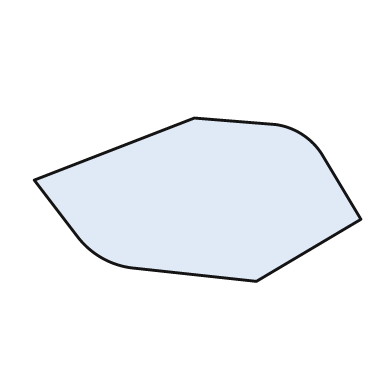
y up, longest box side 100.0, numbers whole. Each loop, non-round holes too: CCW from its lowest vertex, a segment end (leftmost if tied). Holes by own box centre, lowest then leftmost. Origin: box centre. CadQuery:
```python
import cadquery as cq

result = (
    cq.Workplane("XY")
    .moveTo(18.0, -25.0)
    .lineTo(50.0, -6.0)
    .lineTo(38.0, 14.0)
    .threePointArc((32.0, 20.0), (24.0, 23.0))
    .lineTo(-1.0, 25.0)
    .lineTo(-50.0, 6.0)
    .lineTo(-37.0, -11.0)
    .threePointArc((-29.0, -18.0), (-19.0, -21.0))
    .close()
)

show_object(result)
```